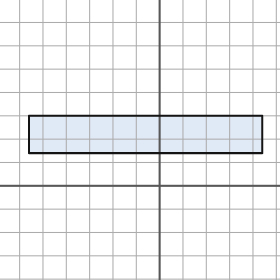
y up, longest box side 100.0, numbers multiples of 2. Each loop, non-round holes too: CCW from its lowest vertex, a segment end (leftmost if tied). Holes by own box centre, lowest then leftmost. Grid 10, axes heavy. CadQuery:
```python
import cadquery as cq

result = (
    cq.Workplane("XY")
    .moveTo(-56.0, 14.0)
    .lineTo(44.0, 14.0)
    .lineTo(44.0, 30.0)
    .lineTo(-56.0, 30.0)
    .close()
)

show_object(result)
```